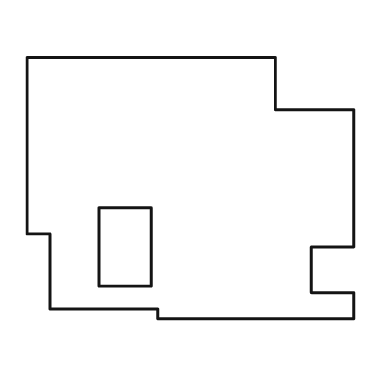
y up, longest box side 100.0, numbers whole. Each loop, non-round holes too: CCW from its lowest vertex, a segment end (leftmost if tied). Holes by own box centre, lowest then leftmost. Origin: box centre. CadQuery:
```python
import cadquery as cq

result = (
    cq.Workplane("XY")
    .moveTo(-10.0, -40.0)
    .lineTo(50.0, -40.0)
    .lineTo(50.0, -32.0)
    .lineTo(37.0, -32.0)
    .lineTo(37.0, -18.0)
    .lineTo(50.0, -18.0)
    .lineTo(50.0, 24.0)
    .lineTo(26.0, 24.0)
    .lineTo(26.0, 40.0)
    .lineTo(-50.0, 40.0)
    .lineTo(-50.0, -14.0)
    .lineTo(-43.0, -14.0)
    .lineTo(-43.0, -37.0)
    .lineTo(-10.0, -37.0)
    .close()
    .moveTo(-28.0, -30.0)
    .lineTo(-12.0, -30.0)
    .lineTo(-12.0, -6.0)
    .lineTo(-28.0, -6.0)
    .close()
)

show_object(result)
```